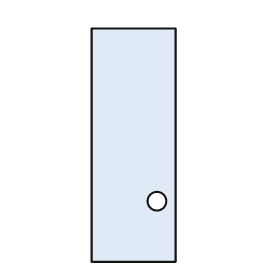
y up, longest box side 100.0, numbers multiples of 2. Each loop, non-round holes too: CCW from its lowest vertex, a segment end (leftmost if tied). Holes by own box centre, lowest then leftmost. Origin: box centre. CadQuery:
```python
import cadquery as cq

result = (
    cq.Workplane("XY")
    .moveTo(-18.0, -50.0)
    .lineTo(18.0, -50.0)
    .lineTo(18.0, 50.0)
    .lineTo(-18.0, 50.0)
    .close()
    .moveTo(10.0, -24.0)
    .circle(4.0)
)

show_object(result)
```